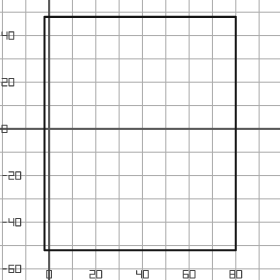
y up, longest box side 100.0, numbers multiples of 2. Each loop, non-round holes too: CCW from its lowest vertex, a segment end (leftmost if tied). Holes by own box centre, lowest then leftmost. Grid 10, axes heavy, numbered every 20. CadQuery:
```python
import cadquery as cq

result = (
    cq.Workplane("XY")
    .moveTo(-2.0, -52.0)
    .lineTo(80.0, -52.0)
    .lineTo(80.0, 48.0)
    .lineTo(-2.0, 48.0)
    .close()
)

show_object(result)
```